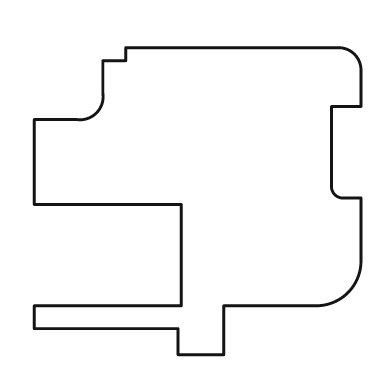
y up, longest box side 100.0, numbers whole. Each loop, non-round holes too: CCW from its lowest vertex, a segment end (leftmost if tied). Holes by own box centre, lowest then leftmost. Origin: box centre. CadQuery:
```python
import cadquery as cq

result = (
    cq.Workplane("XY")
    .moveTo(-6.0, -47.0)
    .lineTo(8.0, -47.0)
    .lineTo(8.0, -32.0)
    .lineTo(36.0, -32.0)
    .threePointArc((46.0, -28.0), (50.0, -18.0))
    .lineTo(50.0, 1.0)
    .lineTo(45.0, 1.0)
    .threePointArc((42.0, 2.0), (41.0, 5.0))
    .lineTo(41.0, 29.0)
    .lineTo(50.0, 29.0)
    .lineTo(50.0, 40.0)
    .threePointArc((48.0, 45.0), (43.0, 47.0))
    .lineTo(-22.0, 47.0)
    .lineTo(-22.0, 43.0)
    .lineTo(-29.0, 43.0)
    .lineTo(-29.0, 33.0)
    .threePointArc((-31.0, 27.0), (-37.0, 25.0))
    .lineTo(-50.0, 25.0)
    .lineTo(-50.0, -1.0)
    .lineTo(-5.0, -1.0)
    .lineTo(-5.0, -32.0)
    .lineTo(-50.0, -32.0)
    .lineTo(-50.0, -39.0)
    .lineTo(-6.0, -39.0)
    .close()
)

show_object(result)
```